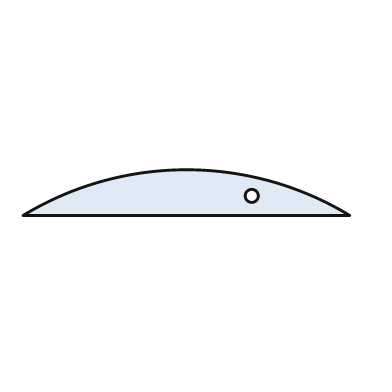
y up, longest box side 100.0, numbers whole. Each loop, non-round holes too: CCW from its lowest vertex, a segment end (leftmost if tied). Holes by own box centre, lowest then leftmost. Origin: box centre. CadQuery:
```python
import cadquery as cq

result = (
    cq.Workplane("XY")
    .moveTo(-50.0, -7.0)
    .lineTo(50.0, -7.0)
    .threePointArc((0.0, 7.0), (-50.0, -7.0))
    .close()
    .moveTo(20.0, -1.0)
    .circle(2.0)
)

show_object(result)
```